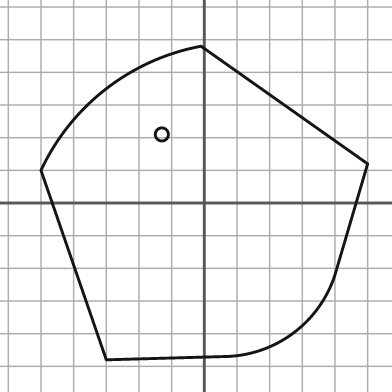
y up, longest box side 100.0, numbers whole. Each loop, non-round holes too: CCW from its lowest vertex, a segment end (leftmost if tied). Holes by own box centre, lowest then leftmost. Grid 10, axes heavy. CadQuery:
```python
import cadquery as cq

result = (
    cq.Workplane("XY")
    .moveTo(-30.0, -48.0)
    .lineTo(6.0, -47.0)
    .threePointArc((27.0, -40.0), (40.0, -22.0))
    .lineTo(50.0, 12.0)
    .lineTo(-1.0, 48.0)
    .threePointArc((-30.0, 35.0), (-50.0, 10.0))
    .close()
    .moveTo(-13.0, 21.0)
    .circle(2.0)
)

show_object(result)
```